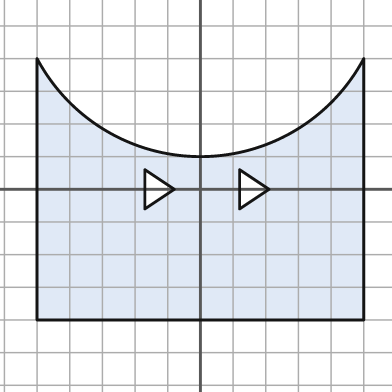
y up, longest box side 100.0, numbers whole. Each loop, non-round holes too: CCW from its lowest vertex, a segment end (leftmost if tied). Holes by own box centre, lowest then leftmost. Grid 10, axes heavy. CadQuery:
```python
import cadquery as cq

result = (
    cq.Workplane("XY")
    .moveTo(-50.0, -40.0)
    .lineTo(50.0, -40.0)
    .lineTo(50.0, 40.0)
    .threePointArc((0.0, 10.0), (-50.0, 40.0))
    .close()
    .moveTo(-17.0, -6.0)
    .lineTo(-8.0, 0.0)
    .lineTo(-17.0, 6.0)
    .close()
    .moveTo(12.0, -6.0)
    .lineTo(21.0, 0.0)
    .lineTo(12.0, 6.0)
    .close()
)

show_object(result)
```